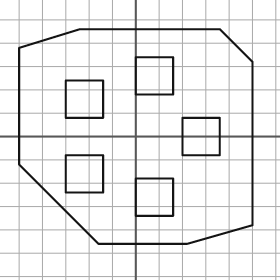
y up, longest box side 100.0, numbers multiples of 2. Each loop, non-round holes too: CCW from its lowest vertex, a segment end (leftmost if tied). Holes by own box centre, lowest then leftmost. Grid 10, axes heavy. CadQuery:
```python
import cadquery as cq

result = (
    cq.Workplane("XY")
    .moveTo(-16.0, -46.0)
    .lineTo(22.0, -46.0)
    .lineTo(50.0, -38.0)
    .lineTo(50.0, 32.0)
    .lineTo(36.0, 46.0)
    .lineTo(-24.0, 46.0)
    .lineTo(-50.0, 38.0)
    .lineTo(-50.0, -12.0)
    .close()
    .moveTo(0.0, -34.0)
    .lineTo(16.0, -34.0)
    .lineTo(16.0, -18.0)
    .lineTo(0.0, -18.0)
    .close()
    .moveTo(-30.0, -24.0)
    .lineTo(-14.0, -24.0)
    .lineTo(-14.0, -8.0)
    .lineTo(-30.0, -8.0)
    .close()
    .moveTo(20.0, -8.0)
    .lineTo(36.0, -8.0)
    .lineTo(36.0, 8.0)
    .lineTo(20.0, 8.0)
    .close()
    .moveTo(-30.0, 8.0)
    .lineTo(-14.0, 8.0)
    .lineTo(-14.0, 24.0)
    .lineTo(-30.0, 24.0)
    .close()
    .moveTo(0.0, 18.0)
    .lineTo(16.0, 18.0)
    .lineTo(16.0, 34.0)
    .lineTo(0.0, 34.0)
    .close()
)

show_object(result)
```